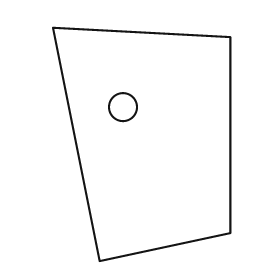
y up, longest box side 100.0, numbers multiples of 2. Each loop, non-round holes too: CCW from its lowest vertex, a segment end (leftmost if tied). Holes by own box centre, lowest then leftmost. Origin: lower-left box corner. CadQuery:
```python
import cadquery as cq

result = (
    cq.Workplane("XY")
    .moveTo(20.0, 0.0)
    .lineTo(76.0, 12.0)
    .lineTo(76.0, 96.0)
    .lineTo(0.0, 100.0)
    .close()
    .moveTo(30.0, 66.0)
    .circle(6.0)
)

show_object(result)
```